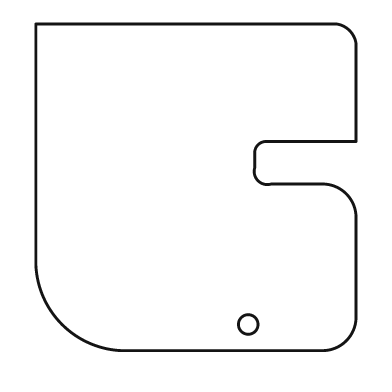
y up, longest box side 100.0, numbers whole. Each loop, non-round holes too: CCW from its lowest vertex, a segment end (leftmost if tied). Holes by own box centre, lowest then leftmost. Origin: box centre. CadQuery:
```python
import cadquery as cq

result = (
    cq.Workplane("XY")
    .moveTo(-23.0, -50.0)
    .lineTo(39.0, -50.0)
    .threePointArc((46.0, -47.0), (49.0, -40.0))
    .lineTo(49.0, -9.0)
    .threePointArc((46.0, -2.0), (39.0, 1.0))
    .lineTo(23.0, 1.0)
    .threePointArc((19.0, 2.0), (18.0, 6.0))
    .lineTo(18.0, 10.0)
    .threePointArc((19.0, 13.0), (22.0, 14.0))
    .lineTo(49.0, 14.0)
    .lineTo(49.0, 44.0)
    .threePointArc((47.0, 48.0), (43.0, 50.0))
    .lineTo(-49.0, 50.0)
    .lineTo(-49.0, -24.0)
    .threePointArc((-41.0, -42.0), (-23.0, -50.0))
    .close()
    .moveTo(16.0, -42.0)
    .circle(3.0)
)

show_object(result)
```